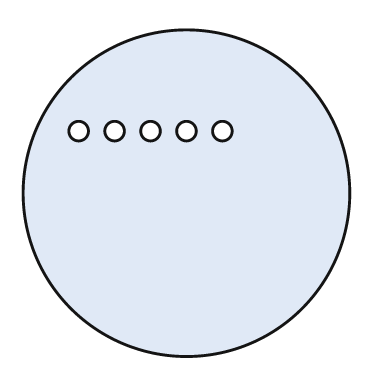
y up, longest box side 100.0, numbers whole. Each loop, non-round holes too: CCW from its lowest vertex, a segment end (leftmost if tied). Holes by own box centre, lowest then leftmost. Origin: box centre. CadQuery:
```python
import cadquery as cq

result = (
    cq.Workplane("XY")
    .moveTo(0.0, 0.0)
    .circle(50.0)
    .moveTo(-33.0, 19.0)
    .circle(3.0)
    .moveTo(-22.0, 19.0)
    .circle(3.0)
    .moveTo(-11.0, 19.0)
    .circle(3.0)
    .moveTo(0.0, 19.0)
    .circle(3.0)
    .moveTo(11.0, 19.0)
    .circle(3.0)
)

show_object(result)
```